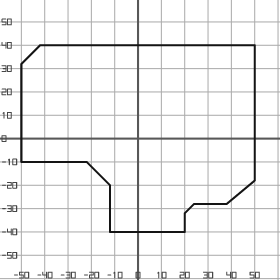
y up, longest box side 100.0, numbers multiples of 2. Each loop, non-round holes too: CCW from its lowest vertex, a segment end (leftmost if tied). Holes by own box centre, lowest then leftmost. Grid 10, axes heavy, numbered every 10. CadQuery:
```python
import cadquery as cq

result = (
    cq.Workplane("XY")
    .moveTo(-12.0, -40.0)
    .lineTo(20.0, -40.0)
    .lineTo(20.0, -32.0)
    .lineTo(24.0, -28.0)
    .lineTo(38.0, -28.0)
    .lineTo(50.0, -18.0)
    .lineTo(50.0, 40.0)
    .lineTo(-42.0, 40.0)
    .lineTo(-50.0, 32.0)
    .lineTo(-50.0, -10.0)
    .lineTo(-22.0, -10.0)
    .lineTo(-12.0, -20.0)
    .close()
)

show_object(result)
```